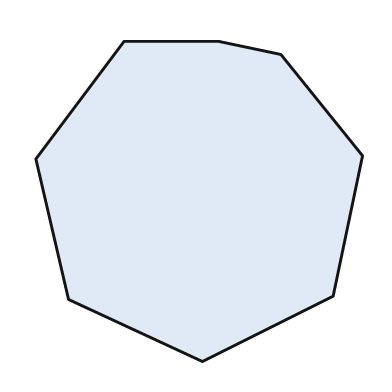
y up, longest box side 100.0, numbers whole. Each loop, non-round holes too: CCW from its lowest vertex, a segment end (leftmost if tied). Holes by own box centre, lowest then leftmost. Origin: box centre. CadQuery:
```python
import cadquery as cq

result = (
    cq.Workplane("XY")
    .moveTo(1.0, -49.0)
    .lineTo(41.0, -29.0)
    .lineTo(50.0, 14.0)
    .lineTo(25.0, 45.0)
    .lineTo(6.0, 49.0)
    .lineTo(-23.0, 49.0)
    .lineTo(-50.0, 13.0)
    .lineTo(-40.0, -30.0)
    .close()
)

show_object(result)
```